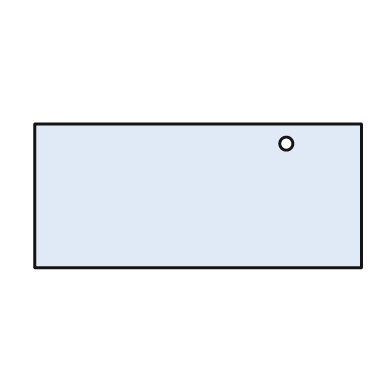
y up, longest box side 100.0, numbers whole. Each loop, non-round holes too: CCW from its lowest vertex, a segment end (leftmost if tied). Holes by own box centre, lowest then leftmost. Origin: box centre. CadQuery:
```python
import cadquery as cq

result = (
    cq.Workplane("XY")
    .moveTo(-50.0, -22.0)
    .lineTo(50.0, -22.0)
    .lineTo(50.0, 22.0)
    .lineTo(-50.0, 22.0)
    .close()
    .moveTo(27.0, 16.0)
    .circle(2.0)
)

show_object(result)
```